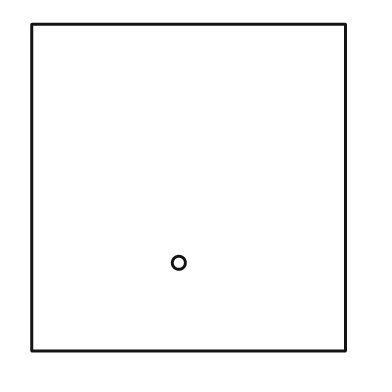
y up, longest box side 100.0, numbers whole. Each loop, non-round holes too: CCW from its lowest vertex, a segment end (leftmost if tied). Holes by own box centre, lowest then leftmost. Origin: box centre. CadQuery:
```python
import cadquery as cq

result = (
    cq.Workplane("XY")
    .moveTo(-48.0, -50.0)
    .lineTo(48.0, -50.0)
    .lineTo(48.0, 50.0)
    .lineTo(-48.0, 50.0)
    .close()
    .moveTo(-3.0, -23.0)
    .circle(2.0)
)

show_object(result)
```